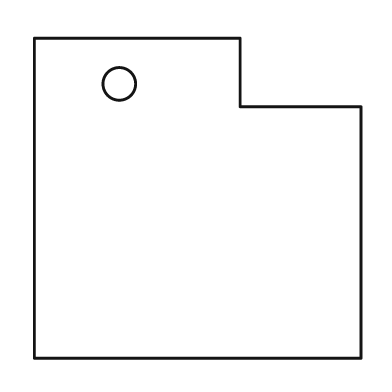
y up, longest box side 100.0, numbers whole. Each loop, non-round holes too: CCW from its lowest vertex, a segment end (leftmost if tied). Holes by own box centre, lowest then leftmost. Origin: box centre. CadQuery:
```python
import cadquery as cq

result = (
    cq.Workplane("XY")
    .moveTo(-50.0, -49.0)
    .lineTo(50.0, -49.0)
    .lineTo(50.0, 28.0)
    .lineTo(13.0, 28.0)
    .lineTo(13.0, 49.0)
    .lineTo(-50.0, 49.0)
    .close()
    .moveTo(-24.0, 35.0)
    .circle(5.0)
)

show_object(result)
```